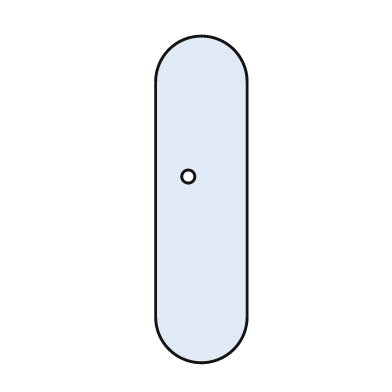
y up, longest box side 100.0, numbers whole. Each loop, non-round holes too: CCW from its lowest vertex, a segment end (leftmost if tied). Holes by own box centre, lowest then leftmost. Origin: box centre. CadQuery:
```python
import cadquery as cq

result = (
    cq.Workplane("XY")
    .moveTo(-14.0, -36.0)
    .threePointArc((0.0, -50.0), (14.0, -36.0))
    .lineTo(14.0, 36.0)
    .threePointArc((0.0, 50.0), (-14.0, 36.0))
    .close()
    .moveTo(-4.0, 7.0)
    .circle(2.0)
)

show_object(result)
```